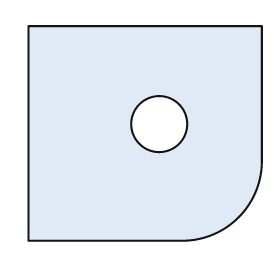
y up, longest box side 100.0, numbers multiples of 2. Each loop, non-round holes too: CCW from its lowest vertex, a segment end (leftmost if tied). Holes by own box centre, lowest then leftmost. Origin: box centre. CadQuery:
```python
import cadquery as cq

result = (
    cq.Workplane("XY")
    .moveTo(-50.0, -46.0)
    .lineTo(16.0, -46.0)
    .threePointArc((40.0, -36.0), (50.0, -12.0))
    .lineTo(50.0, 46.0)
    .lineTo(-50.0, 46.0)
    .close()
    .moveTo(6.0, 4.0)
    .circle(12.0)
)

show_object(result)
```